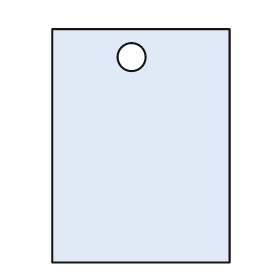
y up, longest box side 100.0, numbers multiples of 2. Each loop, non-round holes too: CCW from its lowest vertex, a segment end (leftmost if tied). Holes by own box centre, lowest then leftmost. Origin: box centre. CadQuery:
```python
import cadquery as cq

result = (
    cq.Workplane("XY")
    .moveTo(-38.0, -50.0)
    .lineTo(38.0, -50.0)
    .lineTo(38.0, 50.0)
    .lineTo(-38.0, 50.0)
    .close()
    .moveTo(-4.0, 38.0)
    .circle(6.0)
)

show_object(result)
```